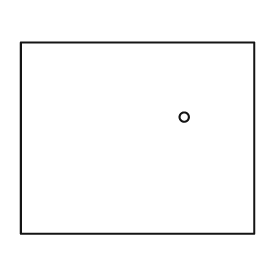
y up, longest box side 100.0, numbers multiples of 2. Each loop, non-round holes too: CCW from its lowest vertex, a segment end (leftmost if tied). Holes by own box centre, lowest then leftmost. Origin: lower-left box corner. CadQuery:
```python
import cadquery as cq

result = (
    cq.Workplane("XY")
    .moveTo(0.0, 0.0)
    .lineTo(100.0, 0.0)
    .lineTo(100.0, 82.0)
    .lineTo(0.0, 82.0)
    .close()
    .moveTo(70.0, 50.0)
    .circle(2.0)
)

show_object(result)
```